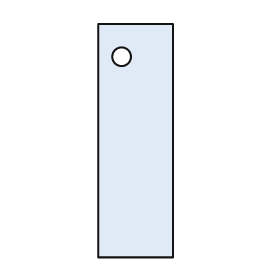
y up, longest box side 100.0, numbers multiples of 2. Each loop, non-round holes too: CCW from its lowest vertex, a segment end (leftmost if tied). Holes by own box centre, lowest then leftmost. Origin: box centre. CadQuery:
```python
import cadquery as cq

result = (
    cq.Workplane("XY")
    .moveTo(-16.0, -50.0)
    .lineTo(16.0, -50.0)
    .lineTo(16.0, 50.0)
    .lineTo(-16.0, 50.0)
    .close()
    .moveTo(-6.0, 36.0)
    .circle(4.0)
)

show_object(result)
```